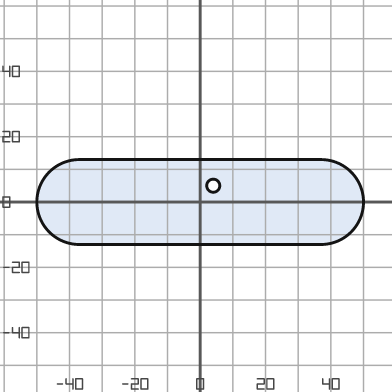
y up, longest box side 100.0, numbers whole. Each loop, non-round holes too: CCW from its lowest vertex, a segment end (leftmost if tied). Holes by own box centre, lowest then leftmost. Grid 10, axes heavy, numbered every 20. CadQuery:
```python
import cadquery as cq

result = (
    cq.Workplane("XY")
    .moveTo(-37.0, -13.0)
    .lineTo(37.0, -13.0)
    .threePointArc((50.0, 0.0), (37.0, 13.0))
    .lineTo(-37.0, 13.0)
    .threePointArc((-50.0, 0.0), (-37.0, -13.0))
    .close()
    .moveTo(4.0, 5.0)
    .circle(2.0)
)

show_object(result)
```